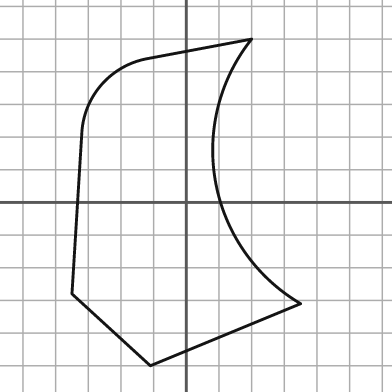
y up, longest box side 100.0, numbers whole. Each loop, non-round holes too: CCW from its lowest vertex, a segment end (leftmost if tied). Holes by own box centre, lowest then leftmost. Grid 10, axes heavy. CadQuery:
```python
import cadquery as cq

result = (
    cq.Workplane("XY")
    .moveTo(-11.0, -50.0)
    .lineTo(35.0, -31.0)
    .threePointArc((9.0, 6.0), (20.0, 50.0))
    .lineTo(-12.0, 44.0)
    .threePointArc((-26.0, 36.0), (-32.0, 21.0))
    .lineTo(-35.0, -28.0)
    .close()
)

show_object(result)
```